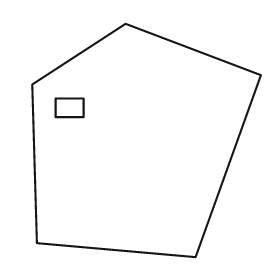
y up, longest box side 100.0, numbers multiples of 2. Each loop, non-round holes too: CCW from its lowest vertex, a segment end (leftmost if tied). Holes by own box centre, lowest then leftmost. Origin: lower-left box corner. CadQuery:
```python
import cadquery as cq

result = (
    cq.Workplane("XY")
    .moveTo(70.0, 0.0)
    .lineTo(98.0, 78.0)
    .lineTo(40.0, 100.0)
    .lineTo(0.0, 74.0)
    .lineTo(2.0, 6.0)
    .close()
    .moveTo(10.0, 60.0)
    .lineTo(22.0, 60.0)
    .lineTo(22.0, 68.0)
    .lineTo(10.0, 68.0)
    .close()
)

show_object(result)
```